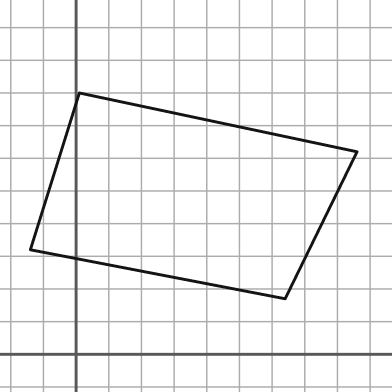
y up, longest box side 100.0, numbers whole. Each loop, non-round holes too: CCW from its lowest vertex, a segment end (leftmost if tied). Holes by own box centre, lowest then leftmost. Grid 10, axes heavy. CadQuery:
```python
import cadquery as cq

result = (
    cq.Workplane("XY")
    .moveTo(64.0, 17.0)
    .lineTo(86.0, 62.0)
    .lineTo(1.0, 80.0)
    .lineTo(-14.0, 32.0)
    .close()
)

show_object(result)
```